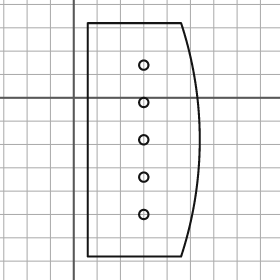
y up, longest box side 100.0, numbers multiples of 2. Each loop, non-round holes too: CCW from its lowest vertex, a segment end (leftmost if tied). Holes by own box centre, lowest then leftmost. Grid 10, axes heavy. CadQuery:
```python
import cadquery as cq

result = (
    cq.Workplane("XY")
    .moveTo(6.0, -68.0)
    .lineTo(46.0, -68.0)
    .threePointArc((54.0, -18.0), (46.0, 32.0))
    .lineTo(6.0, 32.0)
    .close()
    .moveTo(30.0, -50.0)
    .circle(2.0)
    .moveTo(30.0, -34.0)
    .circle(2.0)
    .moveTo(30.0, -18.0)
    .circle(2.0)
    .moveTo(30.0, -2.0)
    .circle(2.0)
    .moveTo(30.0, 14.0)
    .circle(2.0)
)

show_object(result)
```